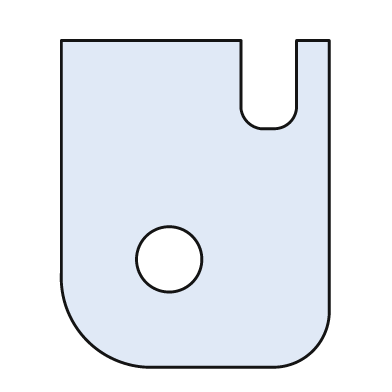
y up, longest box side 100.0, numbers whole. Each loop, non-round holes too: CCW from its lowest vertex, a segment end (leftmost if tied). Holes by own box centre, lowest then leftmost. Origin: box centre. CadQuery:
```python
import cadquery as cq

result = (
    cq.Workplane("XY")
    .moveTo(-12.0, -50.0)
    .lineTo(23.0, -50.0)
    .threePointArc((36.0, -45.0), (41.0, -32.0))
    .lineTo(41.0, 50.0)
    .lineTo(31.0, 50.0)
    .lineTo(31.0, 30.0)
    .threePointArc((29.0, 25.0), (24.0, 23.0))
    .lineTo(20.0, 23.0)
    .threePointArc((16.0, 25.0), (14.0, 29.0))
    .lineTo(14.0, 50.0)
    .lineTo(-41.0, 50.0)
    .lineTo(-41.0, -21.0)
    .threePointArc((-33.0, -42.0), (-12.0, -50.0))
    .close()
    .moveTo(-8.0, -17.0)
    .circle(10.0)
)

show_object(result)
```